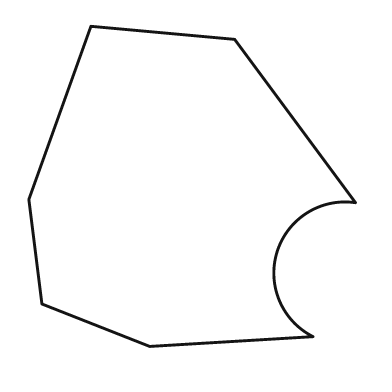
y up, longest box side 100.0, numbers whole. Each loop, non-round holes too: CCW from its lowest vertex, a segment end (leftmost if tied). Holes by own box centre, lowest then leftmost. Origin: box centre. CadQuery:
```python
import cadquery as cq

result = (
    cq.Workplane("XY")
    .moveTo(-13.0, -49.0)
    .lineTo(37.0, -46.0)
    .threePointArc((26.0, -20.0), (50.0, -5.0))
    .lineTo(13.0, 45.0)
    .lineTo(-31.0, 49.0)
    .lineTo(-50.0, -4.0)
    .lineTo(-46.0, -36.0)
    .close()
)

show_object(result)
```